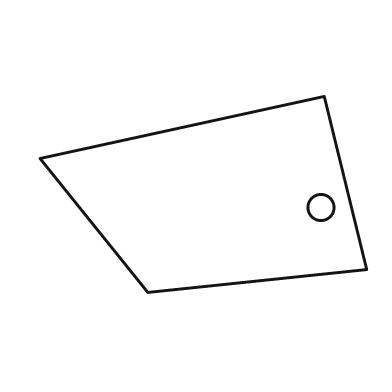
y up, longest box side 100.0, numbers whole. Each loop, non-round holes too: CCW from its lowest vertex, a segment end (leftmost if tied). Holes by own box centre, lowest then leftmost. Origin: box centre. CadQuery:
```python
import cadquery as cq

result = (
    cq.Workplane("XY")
    .moveTo(-17.0, -30.0)
    .lineTo(50.0, -23.0)
    .lineTo(37.0, 30.0)
    .lineTo(-50.0, 11.0)
    .close()
    .moveTo(36.0, -4.0)
    .circle(4.0)
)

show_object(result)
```